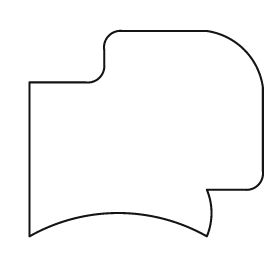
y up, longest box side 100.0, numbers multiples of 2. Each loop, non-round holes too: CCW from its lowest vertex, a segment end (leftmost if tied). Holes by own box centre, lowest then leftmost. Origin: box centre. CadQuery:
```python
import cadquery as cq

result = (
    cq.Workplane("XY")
    .moveTo(-50.0, -44.0)
    .threePointArc((-12.0, -34.0), (26.0, -44.0))
    .threePointArc((28.0, -34.0), (26.0, -24.0))
    .lineTo(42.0, -24.0)
    .threePointArc((48.0, -22.0), (50.0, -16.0))
    .lineTo(50.0, 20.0)
    .threePointArc((42.0, 36.0), (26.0, 44.0))
    .lineTo(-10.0, 44.0)
    .threePointArc((-16.0, 42.0), (-18.0, 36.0))
    .lineTo(-18.0, 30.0)
    .threePointArc((-20.0, 24.0), (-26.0, 22.0))
    .lineTo(-50.0, 22.0)
    .close()
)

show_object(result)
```